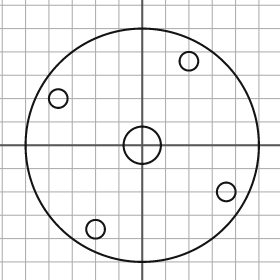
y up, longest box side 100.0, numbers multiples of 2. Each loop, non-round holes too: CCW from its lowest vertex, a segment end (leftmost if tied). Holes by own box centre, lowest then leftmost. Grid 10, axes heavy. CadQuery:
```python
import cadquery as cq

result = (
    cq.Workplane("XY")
    .moveTo(0.0, 0.0)
    .circle(50.0)
    .moveTo(-20.0, -36.0)
    .circle(4.0)
    .moveTo(36.0, -20.0)
    .circle(4.0)
    .moveTo(0.0, 0.0)
    .circle(8.0)
    .moveTo(-36.0, 20.0)
    .circle(4.0)
    .moveTo(20.0, 36.0)
    .circle(4.0)
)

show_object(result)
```